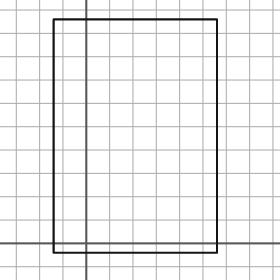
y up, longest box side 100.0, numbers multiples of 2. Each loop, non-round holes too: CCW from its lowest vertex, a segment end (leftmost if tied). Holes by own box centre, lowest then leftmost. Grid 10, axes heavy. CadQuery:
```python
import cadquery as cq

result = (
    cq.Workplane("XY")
    .moveTo(-14.0, -4.0)
    .lineTo(56.0, -4.0)
    .lineTo(56.0, 96.0)
    .lineTo(-14.0, 96.0)
    .close()
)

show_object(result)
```